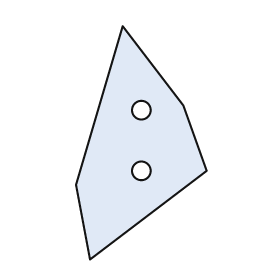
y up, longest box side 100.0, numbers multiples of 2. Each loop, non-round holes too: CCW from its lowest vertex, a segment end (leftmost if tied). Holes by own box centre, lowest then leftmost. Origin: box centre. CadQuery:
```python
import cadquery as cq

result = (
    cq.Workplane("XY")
    .moveTo(-22.0, -50.0)
    .lineTo(28.0, -12.0)
    .lineTo(18.0, 16.0)
    .lineTo(-8.0, 50.0)
    .lineTo(-28.0, -18.0)
    .close()
    .moveTo(0.0, -12.0)
    .circle(4.0)
    .moveTo(0.0, 14.0)
    .circle(4.0)
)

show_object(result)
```